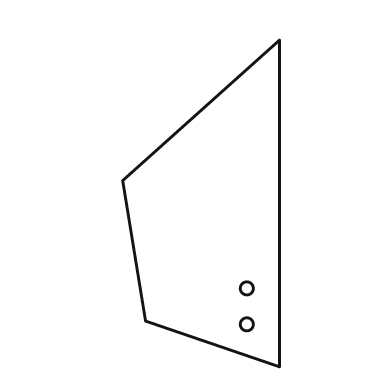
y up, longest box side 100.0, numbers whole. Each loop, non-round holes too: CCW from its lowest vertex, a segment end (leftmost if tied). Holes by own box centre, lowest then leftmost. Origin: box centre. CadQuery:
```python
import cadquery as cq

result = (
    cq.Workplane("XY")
    .moveTo(24.0, -50.0)
    .lineTo(24.0, 50.0)
    .lineTo(-24.0, 7.0)
    .lineTo(-17.0, -36.0)
    .close()
    .moveTo(14.0, -37.0)
    .circle(2.0)
    .moveTo(14.0, -26.0)
    .circle(2.0)
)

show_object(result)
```